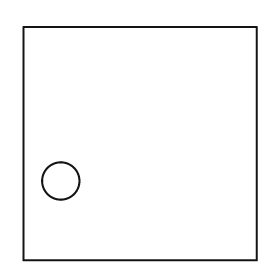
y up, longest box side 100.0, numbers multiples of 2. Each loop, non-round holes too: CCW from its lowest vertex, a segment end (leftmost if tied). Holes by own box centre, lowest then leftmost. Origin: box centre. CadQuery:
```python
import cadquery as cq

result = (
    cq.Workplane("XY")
    .moveTo(-50.0, -50.0)
    .lineTo(50.0, -50.0)
    .lineTo(50.0, 50.0)
    .lineTo(-50.0, 50.0)
    .close()
    .moveTo(-34.0, -16.0)
    .circle(8.0)
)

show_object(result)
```